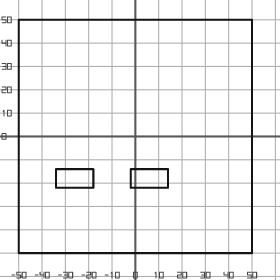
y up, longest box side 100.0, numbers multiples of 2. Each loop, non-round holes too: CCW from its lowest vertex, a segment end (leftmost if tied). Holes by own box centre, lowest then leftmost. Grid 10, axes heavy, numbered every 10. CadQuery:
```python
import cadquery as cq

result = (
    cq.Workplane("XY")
    .moveTo(-50.0, -50.0)
    .lineTo(50.0, -50.0)
    .lineTo(50.0, 50.0)
    .lineTo(-50.0, 50.0)
    .close()
    .moveTo(-34.0, -22.0)
    .lineTo(-18.0, -22.0)
    .lineTo(-18.0, -14.0)
    .lineTo(-34.0, -14.0)
    .close()
    .moveTo(-2.0, -22.0)
    .lineTo(14.0, -22.0)
    .lineTo(14.0, -14.0)
    .lineTo(-2.0, -14.0)
    .close()
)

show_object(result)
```